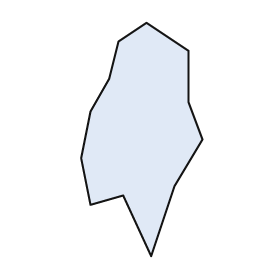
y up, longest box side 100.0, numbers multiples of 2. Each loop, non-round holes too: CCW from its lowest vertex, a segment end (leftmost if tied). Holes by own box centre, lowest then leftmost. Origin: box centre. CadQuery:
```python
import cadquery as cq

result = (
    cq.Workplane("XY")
    .moveTo(4.0, -50.0)
    .lineTo(14.0, -20.0)
    .lineTo(26.0, 0.0)
    .lineTo(20.0, 16.0)
    .lineTo(20.0, 38.0)
    .lineTo(2.0, 50.0)
    .lineTo(-10.0, 42.0)
    .lineTo(-14.0, 26.0)
    .lineTo(-22.0, 12.0)
    .lineTo(-26.0, -8.0)
    .lineTo(-22.0, -28.0)
    .lineTo(-8.0, -24.0)
    .close()
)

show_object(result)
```